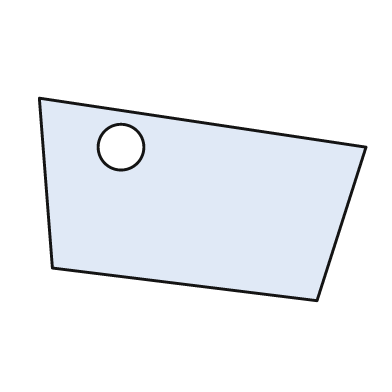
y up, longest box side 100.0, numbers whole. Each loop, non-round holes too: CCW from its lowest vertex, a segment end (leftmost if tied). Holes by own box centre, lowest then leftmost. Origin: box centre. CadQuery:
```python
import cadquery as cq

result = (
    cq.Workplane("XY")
    .moveTo(35.0, -31.0)
    .lineTo(50.0, 16.0)
    .lineTo(-50.0, 31.0)
    .lineTo(-46.0, -21.0)
    .close()
    .moveTo(-25.0, 16.0)
    .circle(7.0)
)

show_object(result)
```